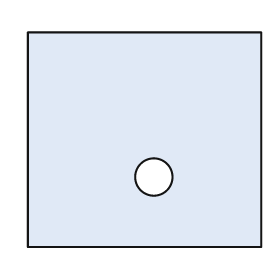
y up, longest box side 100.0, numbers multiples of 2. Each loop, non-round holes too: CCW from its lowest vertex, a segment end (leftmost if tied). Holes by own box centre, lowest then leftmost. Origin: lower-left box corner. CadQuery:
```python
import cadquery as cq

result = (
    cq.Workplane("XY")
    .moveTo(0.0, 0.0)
    .lineTo(100.0, 0.0)
    .lineTo(100.0, 92.0)
    .lineTo(0.0, 92.0)
    .close()
    .moveTo(54.0, 30.0)
    .circle(8.0)
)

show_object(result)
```